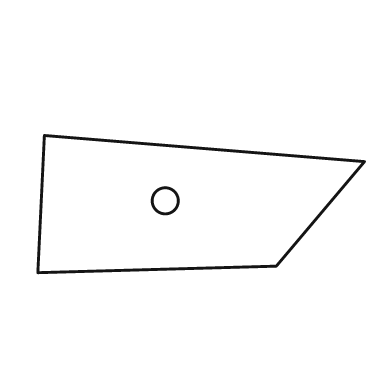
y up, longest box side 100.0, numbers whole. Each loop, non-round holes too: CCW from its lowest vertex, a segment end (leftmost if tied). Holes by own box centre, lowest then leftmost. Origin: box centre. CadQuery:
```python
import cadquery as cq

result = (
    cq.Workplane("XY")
    .moveTo(-50.0, -21.0)
    .lineTo(23.0, -19.0)
    .lineTo(50.0, 13.0)
    .lineTo(-48.0, 21.0)
    .close()
    .moveTo(-11.0, 1.0)
    .circle(4.0)
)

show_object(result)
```